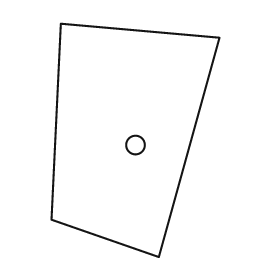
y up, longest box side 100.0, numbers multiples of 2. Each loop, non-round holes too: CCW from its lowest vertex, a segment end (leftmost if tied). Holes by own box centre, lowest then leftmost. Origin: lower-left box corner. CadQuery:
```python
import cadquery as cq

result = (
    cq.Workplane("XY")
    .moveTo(46.0, 0.0)
    .lineTo(72.0, 94.0)
    .lineTo(4.0, 100.0)
    .lineTo(0.0, 16.0)
    .close()
    .moveTo(36.0, 48.0)
    .circle(4.0)
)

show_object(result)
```